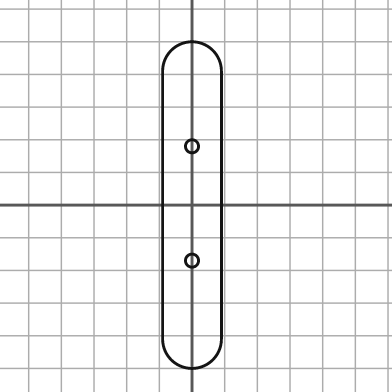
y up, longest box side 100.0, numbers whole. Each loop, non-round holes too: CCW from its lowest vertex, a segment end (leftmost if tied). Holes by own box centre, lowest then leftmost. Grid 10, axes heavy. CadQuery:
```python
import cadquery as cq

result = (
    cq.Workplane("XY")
    .moveTo(-9.0, -41.0)
    .threePointArc((0.0, -50.0), (9.0, -41.0))
    .lineTo(9.0, 41.0)
    .threePointArc((0.0, 50.0), (-9.0, 41.0))
    .close()
    .moveTo(0.0, -17.0)
    .circle(2.0)
    .moveTo(0.0, 18.0)
    .circle(2.0)
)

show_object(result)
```